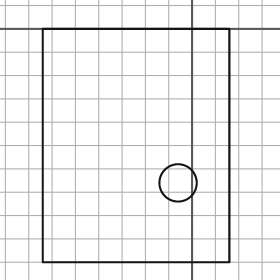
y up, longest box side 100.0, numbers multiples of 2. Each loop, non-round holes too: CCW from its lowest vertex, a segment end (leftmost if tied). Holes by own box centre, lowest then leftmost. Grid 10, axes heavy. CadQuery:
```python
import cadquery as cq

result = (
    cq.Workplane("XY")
    .moveTo(-64.0, -100.0)
    .lineTo(16.0, -100.0)
    .lineTo(16.0, 0.0)
    .lineTo(-64.0, 0.0)
    .close()
    .moveTo(-6.0, -66.0)
    .circle(8.0)
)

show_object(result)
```